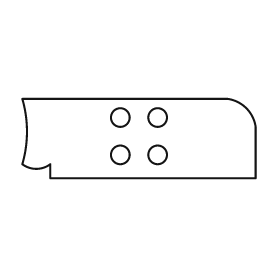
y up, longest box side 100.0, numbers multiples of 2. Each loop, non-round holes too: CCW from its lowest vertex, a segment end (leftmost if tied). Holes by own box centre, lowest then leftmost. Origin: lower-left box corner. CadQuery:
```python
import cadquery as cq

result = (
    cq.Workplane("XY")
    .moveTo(12.0, 0.0)
    .lineTo(100.0, 0.0)
    .lineTo(100.0, 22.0)
    .threePointArc((96.0, 30.0), (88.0, 34.0))
    .lineTo(0.0, 34.0)
    .threePointArc((2.0, 20.0), (0.0, 6.0))
    .threePointArc((6.0, 4.0), (12.0, 6.0))
    .close()
    .moveTo(42.0, 10.0)
    .circle(4.0)
    .moveTo(58.0, 10.0)
    .circle(4.0)
    .moveTo(42.0, 26.0)
    .circle(4.0)
    .moveTo(58.0, 26.0)
    .circle(4.0)
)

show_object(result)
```